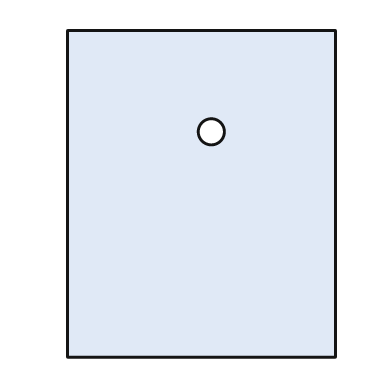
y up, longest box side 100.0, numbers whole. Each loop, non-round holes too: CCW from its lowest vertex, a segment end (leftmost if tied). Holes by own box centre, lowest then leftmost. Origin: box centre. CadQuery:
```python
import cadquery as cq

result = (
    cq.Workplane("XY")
    .moveTo(-41.0, -50.0)
    .lineTo(41.0, -50.0)
    .lineTo(41.0, 50.0)
    .lineTo(-41.0, 50.0)
    .close()
    .moveTo(3.0, 19.0)
    .circle(4.0)
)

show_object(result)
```